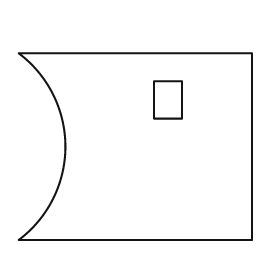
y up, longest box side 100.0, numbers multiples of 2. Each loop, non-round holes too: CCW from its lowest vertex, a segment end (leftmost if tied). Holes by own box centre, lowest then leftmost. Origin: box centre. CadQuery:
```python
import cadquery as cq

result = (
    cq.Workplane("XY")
    .moveTo(-50.0, -40.0)
    .lineTo(50.0, -40.0)
    .lineTo(50.0, 40.0)
    .lineTo(-50.0, 40.0)
    .threePointArc((-30.0, 0.0), (-50.0, -40.0))
    .close()
    .moveTo(8.0, 12.0)
    .lineTo(20.0, 12.0)
    .lineTo(20.0, 28.0)
    .lineTo(8.0, 28.0)
    .close()
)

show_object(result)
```